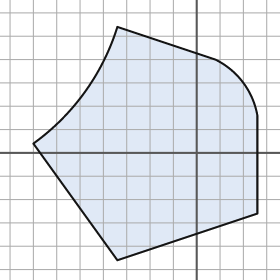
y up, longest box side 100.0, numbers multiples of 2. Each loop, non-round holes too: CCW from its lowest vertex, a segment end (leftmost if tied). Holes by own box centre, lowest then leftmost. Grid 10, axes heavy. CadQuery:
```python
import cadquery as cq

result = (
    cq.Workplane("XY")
    .moveTo(-34.0, -46.0)
    .lineTo(26.0, -26.0)
    .lineTo(26.0, 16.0)
    .threePointArc((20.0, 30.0), (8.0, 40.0))
    .lineTo(-34.0, 54.0)
    .threePointArc((-48.0, 26.0), (-70.0, 4.0))
    .close()
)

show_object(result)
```